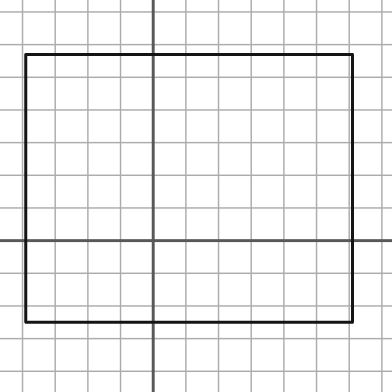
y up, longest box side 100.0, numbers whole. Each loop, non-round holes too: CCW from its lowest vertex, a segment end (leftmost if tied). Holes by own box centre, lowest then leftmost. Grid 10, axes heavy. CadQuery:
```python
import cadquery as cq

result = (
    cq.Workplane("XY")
    .moveTo(-39.0, -25.0)
    .lineTo(61.0, -25.0)
    .lineTo(61.0, 57.0)
    .lineTo(-39.0, 57.0)
    .close()
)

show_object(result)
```